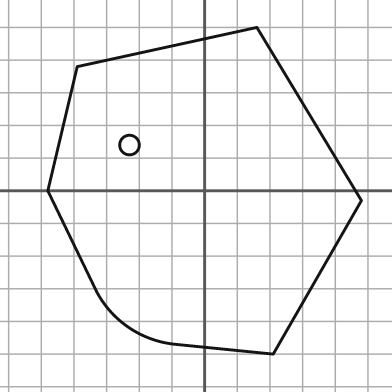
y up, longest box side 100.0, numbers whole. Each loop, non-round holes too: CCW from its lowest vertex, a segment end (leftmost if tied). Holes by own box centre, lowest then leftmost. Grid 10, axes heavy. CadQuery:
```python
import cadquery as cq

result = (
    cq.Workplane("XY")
    .moveTo(21.0, -50.0)
    .lineTo(48.0, -3.0)
    .lineTo(16.0, 50.0)
    .lineTo(-39.0, 38.0)
    .lineTo(-48.0, 0.0)
    .lineTo(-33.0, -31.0)
    .threePointArc((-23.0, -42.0), (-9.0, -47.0))
    .close()
    .moveTo(-23.0, 14.0)
    .circle(3.0)
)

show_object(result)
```